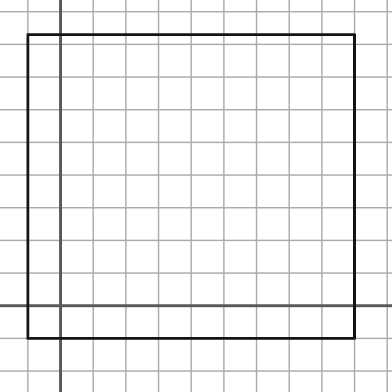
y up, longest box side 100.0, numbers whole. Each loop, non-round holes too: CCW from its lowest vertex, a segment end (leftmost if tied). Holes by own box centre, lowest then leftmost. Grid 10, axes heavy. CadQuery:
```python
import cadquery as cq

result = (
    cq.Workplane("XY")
    .moveTo(-10.0, -10.0)
    .lineTo(90.0, -10.0)
    .lineTo(90.0, 83.0)
    .lineTo(-10.0, 83.0)
    .close()
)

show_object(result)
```